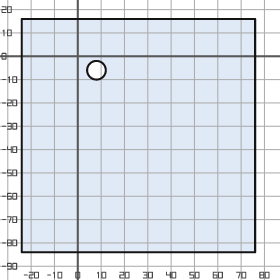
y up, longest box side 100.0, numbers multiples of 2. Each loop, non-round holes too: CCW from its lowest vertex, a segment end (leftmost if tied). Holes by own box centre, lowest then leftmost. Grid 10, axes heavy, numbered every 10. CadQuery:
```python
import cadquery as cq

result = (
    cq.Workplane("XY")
    .moveTo(-24.0, -84.0)
    .lineTo(76.0, -84.0)
    .lineTo(76.0, 16.0)
    .lineTo(-24.0, 16.0)
    .close()
    .moveTo(8.0, -6.0)
    .circle(4.0)
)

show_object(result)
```